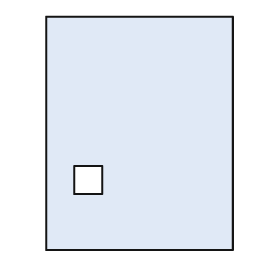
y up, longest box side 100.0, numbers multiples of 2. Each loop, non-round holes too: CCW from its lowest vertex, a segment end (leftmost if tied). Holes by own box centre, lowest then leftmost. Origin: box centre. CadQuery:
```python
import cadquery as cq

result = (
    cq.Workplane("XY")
    .moveTo(-40.0, -50.0)
    .lineTo(40.0, -50.0)
    .lineTo(40.0, 50.0)
    .lineTo(-40.0, 50.0)
    .close()
    .moveTo(-28.0, -26.0)
    .lineTo(-16.0, -26.0)
    .lineTo(-16.0, -14.0)
    .lineTo(-28.0, -14.0)
    .close()
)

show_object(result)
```